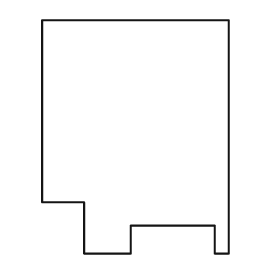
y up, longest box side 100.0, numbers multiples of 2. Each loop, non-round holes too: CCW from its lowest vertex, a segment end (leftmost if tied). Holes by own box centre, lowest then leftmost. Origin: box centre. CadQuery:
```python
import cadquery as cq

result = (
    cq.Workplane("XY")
    .moveTo(-22.0, -50.0)
    .lineTo(-2.0, -50.0)
    .lineTo(-2.0, -38.0)
    .lineTo(34.0, -38.0)
    .lineTo(34.0, -50.0)
    .lineTo(40.0, -50.0)
    .lineTo(40.0, 50.0)
    .lineTo(-40.0, 50.0)
    .lineTo(-40.0, -28.0)
    .lineTo(-22.0, -28.0)
    .close()
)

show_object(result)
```